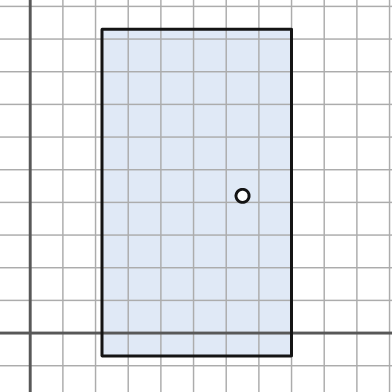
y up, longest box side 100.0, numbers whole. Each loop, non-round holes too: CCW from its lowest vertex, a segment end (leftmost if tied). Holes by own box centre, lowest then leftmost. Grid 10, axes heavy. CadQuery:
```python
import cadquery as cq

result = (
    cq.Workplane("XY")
    .moveTo(22.0, -7.0)
    .lineTo(80.0, -7.0)
    .lineTo(80.0, 93.0)
    .lineTo(22.0, 93.0)
    .close()
    .moveTo(65.0, 42.0)
    .circle(2.0)
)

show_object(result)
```